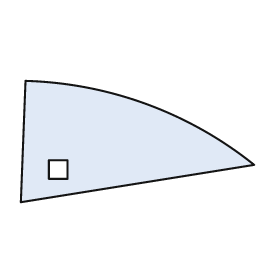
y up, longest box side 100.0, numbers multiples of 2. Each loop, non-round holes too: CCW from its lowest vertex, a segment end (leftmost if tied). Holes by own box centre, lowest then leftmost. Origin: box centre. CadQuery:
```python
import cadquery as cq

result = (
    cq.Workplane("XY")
    .moveTo(-50.0, -26.0)
    .lineTo(50.0, -10.0)
    .threePointArc((4.0, 16.0), (-48.0, 26.0))
    .close()
    .moveTo(-38.0, -16.0)
    .lineTo(-30.0, -16.0)
    .lineTo(-30.0, -8.0)
    .lineTo(-38.0, -8.0)
    .close()
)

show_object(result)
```